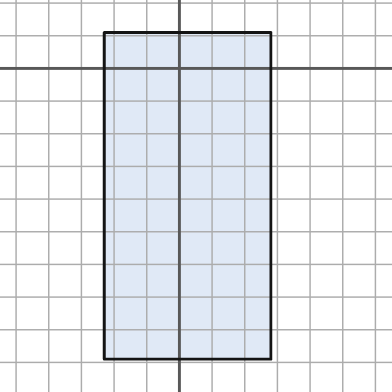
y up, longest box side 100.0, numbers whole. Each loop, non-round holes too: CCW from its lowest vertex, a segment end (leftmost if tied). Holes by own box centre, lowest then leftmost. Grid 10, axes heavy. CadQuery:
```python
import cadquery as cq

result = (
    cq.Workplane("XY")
    .moveTo(-23.0, -89.0)
    .lineTo(28.0, -89.0)
    .lineTo(28.0, 11.0)
    .lineTo(-23.0, 11.0)
    .close()
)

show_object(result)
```